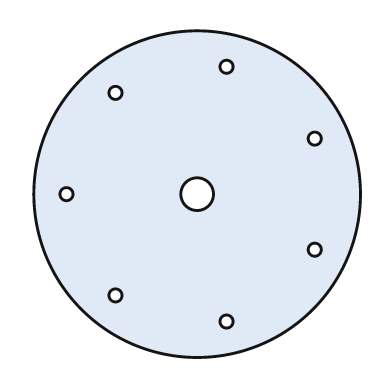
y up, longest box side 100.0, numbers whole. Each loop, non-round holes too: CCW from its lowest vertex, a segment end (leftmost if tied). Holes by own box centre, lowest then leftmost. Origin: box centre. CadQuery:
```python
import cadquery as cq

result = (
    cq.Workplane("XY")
    .moveTo(0.0, 0.0)
    .circle(50.0)
    .moveTo(9.0, -39.0)
    .circle(2.0)
    .moveTo(-25.0, -31.0)
    .circle(2.0)
    .moveTo(36.0, -17.0)
    .circle(2.0)
    .moveTo(-40.0, 0.0)
    .circle(2.0)
    .moveTo(0.0, 0.0)
    .circle(5.0)
    .moveTo(36.0, 17.0)
    .circle(2.0)
    .moveTo(-25.0, 31.0)
    .circle(2.0)
    .moveTo(9.0, 39.0)
    .circle(2.0)
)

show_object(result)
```